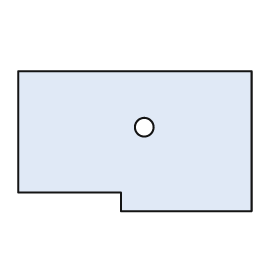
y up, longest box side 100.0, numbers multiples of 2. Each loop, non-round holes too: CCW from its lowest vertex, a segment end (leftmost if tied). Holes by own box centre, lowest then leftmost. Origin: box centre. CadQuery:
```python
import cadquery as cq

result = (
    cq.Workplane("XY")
    .moveTo(-6.0, -30.0)
    .lineTo(50.0, -30.0)
    .lineTo(50.0, 30.0)
    .lineTo(-50.0, 30.0)
    .lineTo(-50.0, -22.0)
    .lineTo(-6.0, -22.0)
    .close()
    .moveTo(4.0, 6.0)
    .circle(4.0)
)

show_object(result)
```